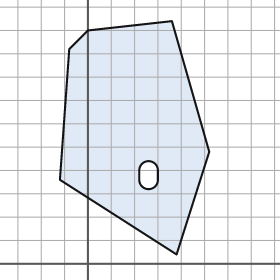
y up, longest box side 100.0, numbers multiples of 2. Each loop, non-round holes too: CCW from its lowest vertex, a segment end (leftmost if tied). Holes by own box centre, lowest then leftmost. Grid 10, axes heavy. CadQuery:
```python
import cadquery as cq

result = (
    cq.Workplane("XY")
    .moveTo(38.0, 4.0)
    .lineTo(52.0, 48.0)
    .lineTo(36.0, 104.0)
    .lineTo(0.0, 100.0)
    .lineTo(-8.0, 92.0)
    .lineTo(-12.0, 36.0)
    .close()
    .moveTo(22.0, 36.0)
    .threePointArc((26.0, 32.0), (30.0, 36.0))
    .lineTo(30.0, 40.0)
    .threePointArc((26.0, 44.0), (22.0, 40.0))
    .close()
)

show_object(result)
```